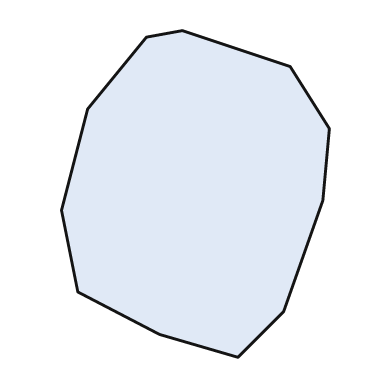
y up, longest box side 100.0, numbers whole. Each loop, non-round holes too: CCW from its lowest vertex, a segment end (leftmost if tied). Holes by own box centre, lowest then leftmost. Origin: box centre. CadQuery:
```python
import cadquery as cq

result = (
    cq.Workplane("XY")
    .moveTo(13.0, -50.0)
    .lineTo(27.0, -36.0)
    .lineTo(39.0, -2.0)
    .lineTo(41.0, 20.0)
    .lineTo(29.0, 39.0)
    .lineTo(-4.0, 50.0)
    .lineTo(-15.0, 48.0)
    .lineTo(-33.0, 26.0)
    .lineTo(-41.0, -5.0)
    .lineTo(-36.0, -30.0)
    .lineTo(-11.0, -43.0)
    .close()
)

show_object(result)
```